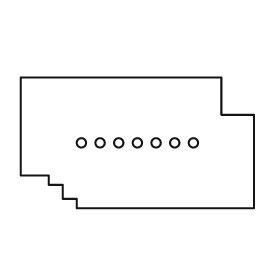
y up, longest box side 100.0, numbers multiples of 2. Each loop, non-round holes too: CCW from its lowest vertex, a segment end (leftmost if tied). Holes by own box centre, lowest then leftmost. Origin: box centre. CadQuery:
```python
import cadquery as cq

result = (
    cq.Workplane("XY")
    .moveTo(-26.0, -28.0)
    .lineTo(50.0, -28.0)
    .lineTo(50.0, 12.0)
    .lineTo(36.0, 12.0)
    .lineTo(36.0, 28.0)
    .lineTo(-50.0, 28.0)
    .lineTo(-50.0, -14.0)
    .lineTo(-38.0, -14.0)
    .lineTo(-38.0, -18.0)
    .lineTo(-32.0, -18.0)
    .lineTo(-32.0, -24.0)
    .lineTo(-26.0, -24.0)
    .close()
    .moveTo(-24.0, 0.0)
    .circle(2.0)
    .moveTo(-16.0, 0.0)
    .circle(2.0)
    .moveTo(-8.0, 0.0)
    .circle(2.0)
    .moveTo(0.0, 0.0)
    .circle(2.0)
    .moveTo(8.0, 0.0)
    .circle(2.0)
    .moveTo(16.0, 0.0)
    .circle(2.0)
    .moveTo(24.0, 0.0)
    .circle(2.0)
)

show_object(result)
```